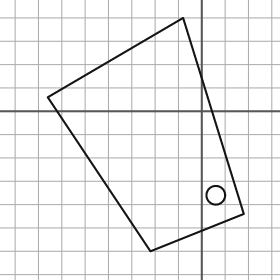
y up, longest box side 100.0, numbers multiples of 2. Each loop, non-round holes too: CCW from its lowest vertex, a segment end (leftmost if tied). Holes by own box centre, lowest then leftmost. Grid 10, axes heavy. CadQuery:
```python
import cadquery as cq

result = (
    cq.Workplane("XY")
    .moveTo(-22.0, -60.0)
    .lineTo(18.0, -44.0)
    .lineTo(-8.0, 40.0)
    .lineTo(-66.0, 6.0)
    .close()
    .moveTo(6.0, -36.0)
    .circle(4.0)
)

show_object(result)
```